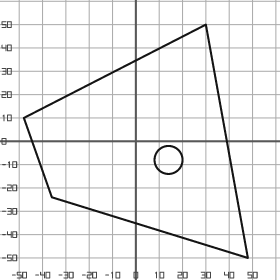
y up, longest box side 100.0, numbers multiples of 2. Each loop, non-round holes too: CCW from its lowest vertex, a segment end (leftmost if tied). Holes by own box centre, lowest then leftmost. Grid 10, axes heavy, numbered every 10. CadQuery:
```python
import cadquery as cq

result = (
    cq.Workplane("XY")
    .moveTo(48.0, -50.0)
    .lineTo(30.0, 50.0)
    .lineTo(-48.0, 10.0)
    .lineTo(-36.0, -24.0)
    .close()
    .moveTo(14.0, -8.0)
    .circle(6.0)
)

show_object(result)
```